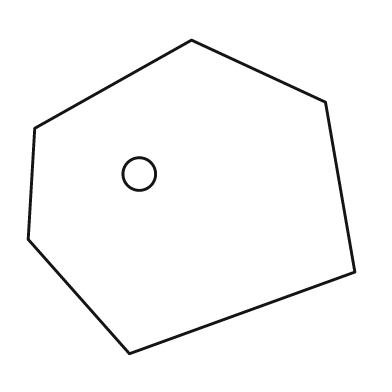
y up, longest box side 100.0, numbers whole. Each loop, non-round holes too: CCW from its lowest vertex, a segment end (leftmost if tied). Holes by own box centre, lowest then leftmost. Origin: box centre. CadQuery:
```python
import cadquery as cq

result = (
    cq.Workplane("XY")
    .moveTo(-19.0, -48.0)
    .lineTo(50.0, -23.0)
    .lineTo(41.0, 29.0)
    .lineTo(0.0, 48.0)
    .lineTo(-48.0, 21.0)
    .lineTo(-50.0, -13.0)
    .close()
    .moveTo(-16.0, 7.0)
    .circle(5.0)
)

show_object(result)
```